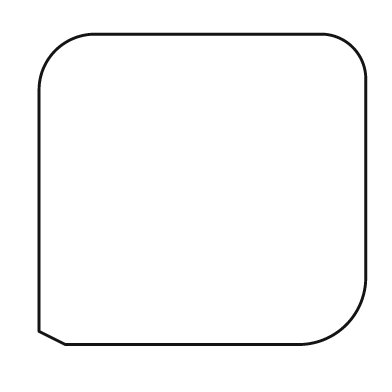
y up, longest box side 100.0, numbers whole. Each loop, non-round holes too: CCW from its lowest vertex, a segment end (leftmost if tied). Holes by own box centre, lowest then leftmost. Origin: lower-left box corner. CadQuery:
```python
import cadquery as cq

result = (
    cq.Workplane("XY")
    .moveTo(8.0, 0.0)
    .lineTo(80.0, 0.0)
    .threePointArc((94.0, 6.0), (100.0, 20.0))
    .lineTo(100.0, 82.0)
    .threePointArc((96.0, 91.0), (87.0, 95.0))
    .lineTo(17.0, 95.0)
    .threePointArc((5.0, 90.0), (0.0, 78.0))
    .lineTo(0.0, 4.0)
    .close()
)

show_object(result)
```